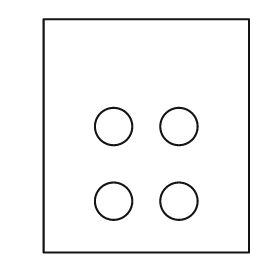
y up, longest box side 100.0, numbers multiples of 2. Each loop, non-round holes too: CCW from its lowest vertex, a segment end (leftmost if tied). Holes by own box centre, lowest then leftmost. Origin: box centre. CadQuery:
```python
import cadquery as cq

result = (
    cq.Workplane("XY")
    .moveTo(-44.0, -50.0)
    .lineTo(44.0, -50.0)
    .lineTo(44.0, 50.0)
    .lineTo(-44.0, 50.0)
    .close()
    .moveTo(-14.0, -28.0)
    .circle(8.0)
    .moveTo(14.0, -28.0)
    .circle(8.0)
    .moveTo(-14.0, 4.0)
    .circle(8.0)
    .moveTo(14.0, 4.0)
    .circle(8.0)
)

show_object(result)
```